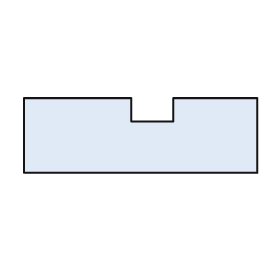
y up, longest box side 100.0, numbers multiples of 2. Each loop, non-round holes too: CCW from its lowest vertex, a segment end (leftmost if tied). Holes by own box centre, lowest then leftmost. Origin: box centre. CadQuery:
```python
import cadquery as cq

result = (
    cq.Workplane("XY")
    .moveTo(-50.0, -16.0)
    .lineTo(50.0, -16.0)
    .lineTo(50.0, 16.0)
    .lineTo(14.0, 16.0)
    .lineTo(14.0, 6.0)
    .lineTo(-4.0, 6.0)
    .lineTo(-4.0, 16.0)
    .lineTo(-50.0, 16.0)
    .close()
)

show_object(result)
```